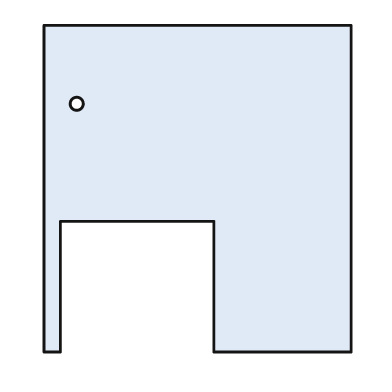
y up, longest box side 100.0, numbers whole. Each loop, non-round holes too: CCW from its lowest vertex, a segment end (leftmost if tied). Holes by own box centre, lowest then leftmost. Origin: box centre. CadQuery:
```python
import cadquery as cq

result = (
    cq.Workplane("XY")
    .moveTo(-47.0, -50.0)
    .lineTo(-42.0, -50.0)
    .lineTo(-42.0, -10.0)
    .lineTo(5.0, -10.0)
    .lineTo(5.0, -50.0)
    .lineTo(47.0, -50.0)
    .lineTo(47.0, 50.0)
    .lineTo(-47.0, 50.0)
    .close()
    .moveTo(-37.0, 26.0)
    .circle(2.0)
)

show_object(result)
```